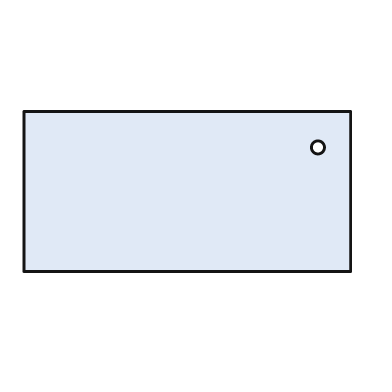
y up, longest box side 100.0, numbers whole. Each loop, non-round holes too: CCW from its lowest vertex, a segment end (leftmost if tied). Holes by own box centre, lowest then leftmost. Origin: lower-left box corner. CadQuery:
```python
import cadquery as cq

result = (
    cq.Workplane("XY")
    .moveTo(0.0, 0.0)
    .lineTo(100.0, 0.0)
    .lineTo(100.0, 49.0)
    .lineTo(0.0, 49.0)
    .close()
    .moveTo(90.0, 38.0)
    .circle(2.0)
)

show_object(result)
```